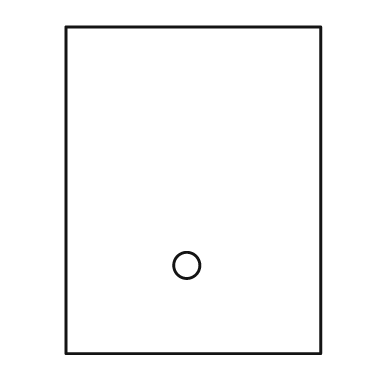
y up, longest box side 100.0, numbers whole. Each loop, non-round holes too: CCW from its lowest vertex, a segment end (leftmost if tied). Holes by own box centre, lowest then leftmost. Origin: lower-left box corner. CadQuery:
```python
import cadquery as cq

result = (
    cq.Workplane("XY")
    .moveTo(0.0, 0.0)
    .lineTo(78.0, 0.0)
    .lineTo(78.0, 100.0)
    .lineTo(0.0, 100.0)
    .close()
    .moveTo(37.0, 27.0)
    .circle(4.0)
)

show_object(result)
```